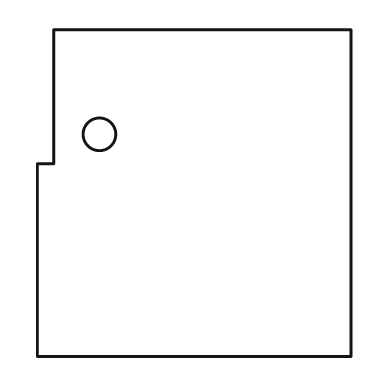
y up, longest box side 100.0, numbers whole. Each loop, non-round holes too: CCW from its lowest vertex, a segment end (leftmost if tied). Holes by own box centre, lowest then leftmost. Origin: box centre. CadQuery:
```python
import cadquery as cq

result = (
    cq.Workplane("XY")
    .moveTo(-48.0, -50.0)
    .lineTo(48.0, -50.0)
    .lineTo(48.0, 50.0)
    .lineTo(-43.0, 50.0)
    .lineTo(-43.0, 9.0)
    .lineTo(-48.0, 9.0)
    .close()
    .moveTo(-29.0, 18.0)
    .circle(5.0)
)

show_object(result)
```